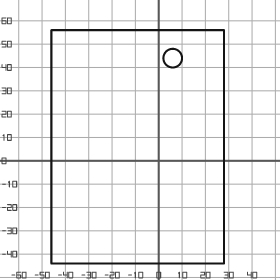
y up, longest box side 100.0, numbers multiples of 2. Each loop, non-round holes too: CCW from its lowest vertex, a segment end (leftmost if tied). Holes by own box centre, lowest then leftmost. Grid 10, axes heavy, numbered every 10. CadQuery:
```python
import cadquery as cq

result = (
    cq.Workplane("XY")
    .moveTo(-46.0, -44.0)
    .lineTo(28.0, -44.0)
    .lineTo(28.0, 56.0)
    .lineTo(-46.0, 56.0)
    .close()
    .moveTo(6.0, 44.0)
    .circle(4.0)
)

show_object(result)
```